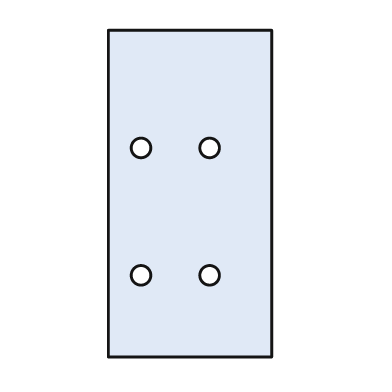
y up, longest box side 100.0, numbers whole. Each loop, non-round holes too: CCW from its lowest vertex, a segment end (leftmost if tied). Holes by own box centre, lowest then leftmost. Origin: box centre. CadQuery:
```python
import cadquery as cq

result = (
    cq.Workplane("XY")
    .moveTo(-25.0, -50.0)
    .lineTo(25.0, -50.0)
    .lineTo(25.0, 50.0)
    .lineTo(-25.0, 50.0)
    .close()
    .moveTo(-15.0, -25.0)
    .circle(3.0)
    .moveTo(6.0, -25.0)
    .circle(3.0)
    .moveTo(-15.0, 14.0)
    .circle(3.0)
    .moveTo(6.0, 14.0)
    .circle(3.0)
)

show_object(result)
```